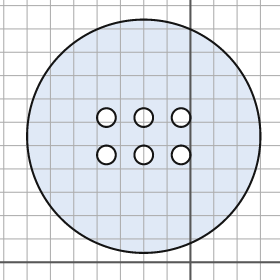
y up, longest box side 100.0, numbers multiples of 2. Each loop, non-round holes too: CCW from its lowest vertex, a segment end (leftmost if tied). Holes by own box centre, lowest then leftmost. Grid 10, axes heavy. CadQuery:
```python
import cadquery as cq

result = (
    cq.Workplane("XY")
    .moveTo(-20.0, 54.0)
    .circle(50.0)
    .moveTo(-36.0, 46.0)
    .circle(4.0)
    .moveTo(-20.0, 46.0)
    .circle(4.0)
    .moveTo(-4.0, 46.0)
    .circle(4.0)
    .moveTo(-36.0, 62.0)
    .circle(4.0)
    .moveTo(-20.0, 62.0)
    .circle(4.0)
    .moveTo(-4.0, 62.0)
    .circle(4.0)
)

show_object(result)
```